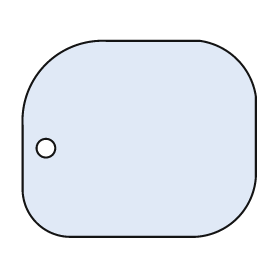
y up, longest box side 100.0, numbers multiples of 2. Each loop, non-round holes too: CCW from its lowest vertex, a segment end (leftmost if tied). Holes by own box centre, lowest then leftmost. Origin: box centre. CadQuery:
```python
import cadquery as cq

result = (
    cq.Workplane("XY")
    .moveTo(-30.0, -42.0)
    .lineTo(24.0, -42.0)
    .threePointArc((42.0, -34.0), (50.0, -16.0))
    .lineTo(50.0, 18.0)
    .threePointArc((42.0, 34.0), (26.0, 42.0))
    .lineTo(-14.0, 42.0)
    .threePointArc((-40.0, 32.0), (-50.0, 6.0))
    .lineTo(-50.0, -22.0)
    .threePointArc((-44.0, -36.0), (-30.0, -42.0))
    .close()
    .moveTo(-40.0, -4.0)
    .circle(4.0)
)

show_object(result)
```